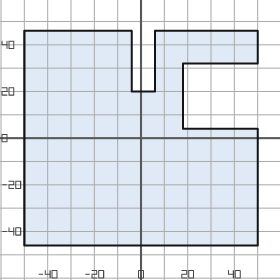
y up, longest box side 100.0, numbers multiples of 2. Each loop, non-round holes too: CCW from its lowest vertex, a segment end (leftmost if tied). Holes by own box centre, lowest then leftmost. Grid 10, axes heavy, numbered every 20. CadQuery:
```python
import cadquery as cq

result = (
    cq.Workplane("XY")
    .moveTo(-50.0, -46.0)
    .lineTo(50.0, -46.0)
    .lineTo(50.0, 4.0)
    .lineTo(18.0, 4.0)
    .lineTo(18.0, 32.0)
    .lineTo(50.0, 32.0)
    .lineTo(50.0, 46.0)
    .lineTo(6.0, 46.0)
    .lineTo(6.0, 20.0)
    .lineTo(-4.0, 20.0)
    .lineTo(-4.0, 46.0)
    .lineTo(-50.0, 46.0)
    .close()
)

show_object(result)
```